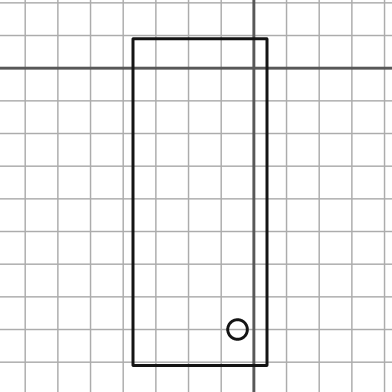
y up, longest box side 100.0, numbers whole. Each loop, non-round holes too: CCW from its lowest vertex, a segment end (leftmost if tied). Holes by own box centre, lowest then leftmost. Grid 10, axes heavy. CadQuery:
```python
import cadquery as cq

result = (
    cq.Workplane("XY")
    .moveTo(-37.0, -91.0)
    .lineTo(4.0, -91.0)
    .lineTo(4.0, 9.0)
    .lineTo(-37.0, 9.0)
    .close()
    .moveTo(-5.0, -80.0)
    .circle(3.0)
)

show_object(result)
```